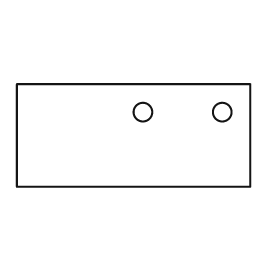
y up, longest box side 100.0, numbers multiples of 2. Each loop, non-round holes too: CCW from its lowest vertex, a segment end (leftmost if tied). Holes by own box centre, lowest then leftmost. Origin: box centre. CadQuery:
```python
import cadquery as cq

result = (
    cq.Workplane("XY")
    .moveTo(-50.0, -22.0)
    .lineTo(50.0, -22.0)
    .lineTo(50.0, 22.0)
    .lineTo(-50.0, 22.0)
    .close()
    .moveTo(4.0, 10.0)
    .circle(4.0)
    .moveTo(38.0, 10.0)
    .circle(4.0)
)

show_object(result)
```